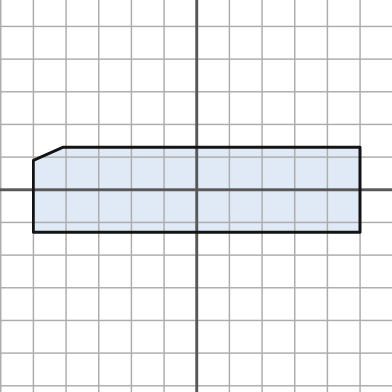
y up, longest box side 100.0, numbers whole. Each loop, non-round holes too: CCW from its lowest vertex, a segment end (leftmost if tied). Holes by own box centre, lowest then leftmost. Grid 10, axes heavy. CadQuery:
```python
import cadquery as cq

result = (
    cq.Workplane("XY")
    .moveTo(-50.0, -13.0)
    .lineTo(50.0, -13.0)
    .lineTo(50.0, 13.0)
    .lineTo(-41.0, 13.0)
    .lineTo(-50.0, 9.0)
    .close()
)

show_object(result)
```